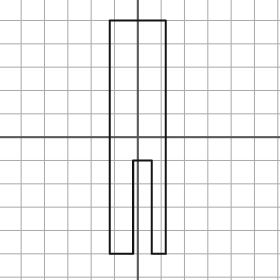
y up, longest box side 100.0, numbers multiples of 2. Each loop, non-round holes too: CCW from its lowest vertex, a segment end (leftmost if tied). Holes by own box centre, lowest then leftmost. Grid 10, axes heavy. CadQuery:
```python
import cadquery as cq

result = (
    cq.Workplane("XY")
    .moveTo(-12.0, -50.0)
    .lineTo(-2.0, -50.0)
    .lineTo(-2.0, -10.0)
    .lineTo(6.0, -10.0)
    .lineTo(6.0, -50.0)
    .lineTo(12.0, -50.0)
    .lineTo(12.0, 50.0)
    .lineTo(-12.0, 50.0)
    .close()
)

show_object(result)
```